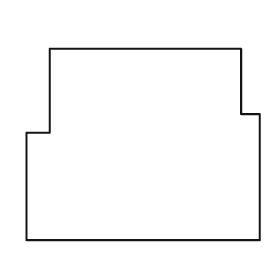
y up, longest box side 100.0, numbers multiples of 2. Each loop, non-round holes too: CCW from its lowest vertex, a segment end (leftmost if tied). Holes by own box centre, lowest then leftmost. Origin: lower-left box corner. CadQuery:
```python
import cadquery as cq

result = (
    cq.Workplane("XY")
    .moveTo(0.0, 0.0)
    .lineTo(100.0, 0.0)
    .lineTo(100.0, 54.0)
    .lineTo(92.0, 54.0)
    .lineTo(92.0, 82.0)
    .lineTo(10.0, 82.0)
    .lineTo(10.0, 46.0)
    .lineTo(0.0, 46.0)
    .close()
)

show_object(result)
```